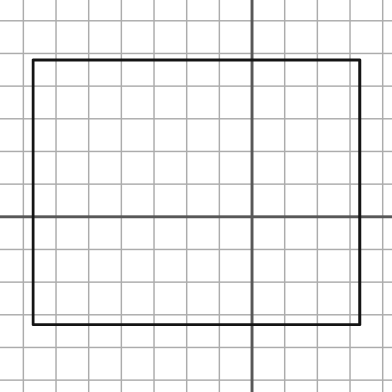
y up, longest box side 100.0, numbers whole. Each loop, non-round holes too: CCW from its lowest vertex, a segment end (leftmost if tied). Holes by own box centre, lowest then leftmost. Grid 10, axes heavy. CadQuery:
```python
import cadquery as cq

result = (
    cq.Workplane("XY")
    .moveTo(-67.0, -33.0)
    .lineTo(33.0, -33.0)
    .lineTo(33.0, 48.0)
    .lineTo(-67.0, 48.0)
    .close()
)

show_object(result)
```